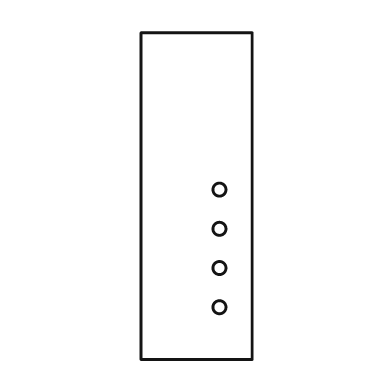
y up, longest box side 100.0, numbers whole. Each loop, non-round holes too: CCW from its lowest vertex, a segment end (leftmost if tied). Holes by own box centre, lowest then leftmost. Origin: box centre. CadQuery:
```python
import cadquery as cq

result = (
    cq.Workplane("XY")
    .moveTo(-17.0, -50.0)
    .lineTo(17.0, -50.0)
    .lineTo(17.0, 50.0)
    .lineTo(-17.0, 50.0)
    .close()
    .moveTo(7.0, -34.0)
    .circle(2.0)
    .moveTo(7.0, -22.0)
    .circle(2.0)
    .moveTo(7.0, -10.0)
    .circle(2.0)
    .moveTo(7.0, 2.0)
    .circle(2.0)
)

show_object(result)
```